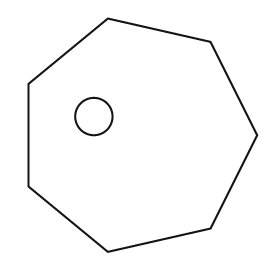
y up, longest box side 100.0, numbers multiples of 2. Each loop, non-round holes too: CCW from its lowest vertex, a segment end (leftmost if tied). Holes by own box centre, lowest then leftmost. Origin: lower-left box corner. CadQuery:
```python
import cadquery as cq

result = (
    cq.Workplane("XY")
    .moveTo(34.0, 0.0)
    .lineTo(78.0, 10.0)
    .lineTo(98.0, 50.0)
    .lineTo(78.0, 90.0)
    .lineTo(34.0, 100.0)
    .lineTo(0.0, 72.0)
    .lineTo(0.0, 28.0)
    .close()
    .moveTo(28.0, 58.0)
    .circle(8.0)
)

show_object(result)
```